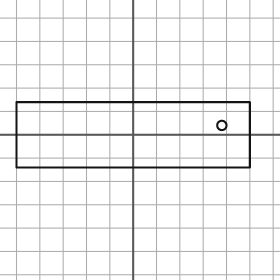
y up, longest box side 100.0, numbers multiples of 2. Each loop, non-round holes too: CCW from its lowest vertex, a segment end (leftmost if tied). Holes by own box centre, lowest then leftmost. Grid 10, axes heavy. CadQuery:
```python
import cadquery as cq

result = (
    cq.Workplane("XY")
    .moveTo(-50.0, -14.0)
    .lineTo(50.0, -14.0)
    .lineTo(50.0, 14.0)
    .lineTo(-50.0, 14.0)
    .close()
    .moveTo(38.0, 4.0)
    .circle(2.0)
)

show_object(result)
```